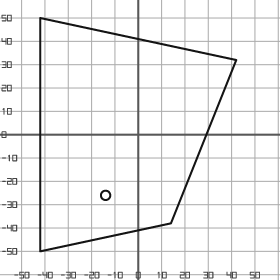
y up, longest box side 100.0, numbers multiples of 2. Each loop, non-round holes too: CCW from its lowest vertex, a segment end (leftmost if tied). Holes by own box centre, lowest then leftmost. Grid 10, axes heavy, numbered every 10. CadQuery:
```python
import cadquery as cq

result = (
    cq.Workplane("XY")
    .moveTo(-42.0, -50.0)
    .lineTo(14.0, -38.0)
    .lineTo(42.0, 32.0)
    .lineTo(-42.0, 50.0)
    .close()
    .moveTo(-14.0, -26.0)
    .circle(2.0)
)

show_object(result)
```